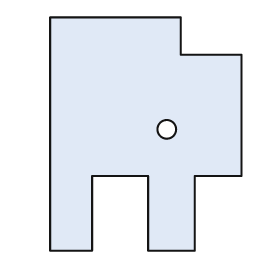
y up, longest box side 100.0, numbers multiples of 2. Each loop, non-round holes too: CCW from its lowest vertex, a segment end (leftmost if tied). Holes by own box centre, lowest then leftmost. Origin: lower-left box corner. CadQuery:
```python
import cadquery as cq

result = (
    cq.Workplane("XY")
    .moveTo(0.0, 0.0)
    .lineTo(18.0, 0.0)
    .lineTo(18.0, 32.0)
    .lineTo(42.0, 32.0)
    .lineTo(42.0, 0.0)
    .lineTo(62.0, 0.0)
    .lineTo(62.0, 32.0)
    .lineTo(82.0, 32.0)
    .lineTo(82.0, 84.0)
    .lineTo(56.0, 84.0)
    .lineTo(56.0, 100.0)
    .lineTo(0.0, 100.0)
    .close()
    .moveTo(50.0, 52.0)
    .circle(4.0)
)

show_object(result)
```